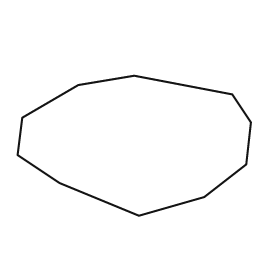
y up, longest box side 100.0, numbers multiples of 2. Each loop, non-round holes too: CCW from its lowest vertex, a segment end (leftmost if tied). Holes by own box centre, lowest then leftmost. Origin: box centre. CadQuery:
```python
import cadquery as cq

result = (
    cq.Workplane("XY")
    .moveTo(2.0, -30.0)
    .lineTo(30.0, -22.0)
    .lineTo(48.0, -8.0)
    .lineTo(50.0, 10.0)
    .lineTo(42.0, 22.0)
    .lineTo(0.0, 30.0)
    .lineTo(-24.0, 26.0)
    .lineTo(-48.0, 12.0)
    .lineTo(-50.0, -4.0)
    .lineTo(-32.0, -16.0)
    .close()
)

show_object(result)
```